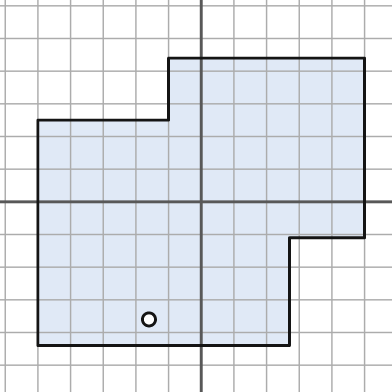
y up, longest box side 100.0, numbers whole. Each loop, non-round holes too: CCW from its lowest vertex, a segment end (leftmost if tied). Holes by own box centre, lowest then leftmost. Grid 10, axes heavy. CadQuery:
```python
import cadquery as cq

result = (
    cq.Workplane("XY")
    .moveTo(-50.0, -44.0)
    .lineTo(27.0, -44.0)
    .lineTo(27.0, -11.0)
    .lineTo(50.0, -11.0)
    .lineTo(50.0, 44.0)
    .lineTo(-10.0, 44.0)
    .lineTo(-10.0, 25.0)
    .lineTo(-50.0, 25.0)
    .close()
    .moveTo(-16.0, -36.0)
    .circle(2.0)
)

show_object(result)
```